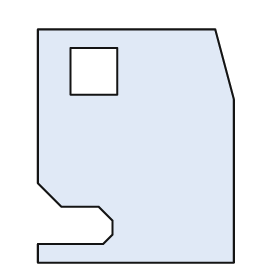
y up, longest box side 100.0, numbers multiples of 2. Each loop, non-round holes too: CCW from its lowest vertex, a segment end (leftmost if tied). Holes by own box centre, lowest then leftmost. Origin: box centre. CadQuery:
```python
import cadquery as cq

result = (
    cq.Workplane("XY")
    .moveTo(-42.0, -50.0)
    .lineTo(42.0, -50.0)
    .lineTo(42.0, 20.0)
    .lineTo(34.0, 50.0)
    .lineTo(-42.0, 50.0)
    .lineTo(-42.0, -16.0)
    .lineTo(-32.0, -26.0)
    .lineTo(-16.0, -26.0)
    .lineTo(-10.0, -32.0)
    .lineTo(-10.0, -38.0)
    .lineTo(-14.0, -42.0)
    .lineTo(-42.0, -42.0)
    .close()
    .moveTo(-28.0, 22.0)
    .lineTo(-8.0, 22.0)
    .lineTo(-8.0, 42.0)
    .lineTo(-28.0, 42.0)
    .close()
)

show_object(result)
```